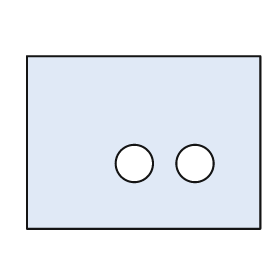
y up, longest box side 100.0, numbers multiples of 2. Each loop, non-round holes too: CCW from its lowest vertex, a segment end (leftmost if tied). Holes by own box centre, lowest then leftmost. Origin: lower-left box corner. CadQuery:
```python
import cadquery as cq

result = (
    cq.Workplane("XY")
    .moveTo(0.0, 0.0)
    .lineTo(100.0, 0.0)
    .lineTo(100.0, 74.0)
    .lineTo(0.0, 74.0)
    .close()
    .moveTo(46.0, 28.0)
    .circle(8.0)
    .moveTo(72.0, 28.0)
    .circle(8.0)
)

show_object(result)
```